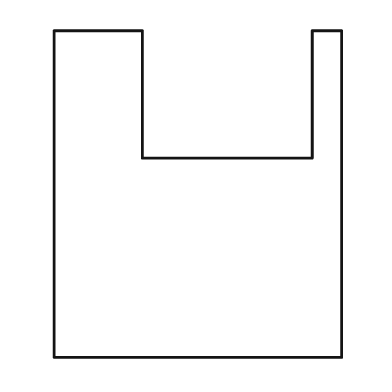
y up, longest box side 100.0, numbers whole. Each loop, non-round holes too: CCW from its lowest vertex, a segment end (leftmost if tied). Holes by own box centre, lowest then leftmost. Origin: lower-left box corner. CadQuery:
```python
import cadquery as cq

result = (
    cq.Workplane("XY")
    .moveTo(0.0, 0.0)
    .lineTo(88.0, 0.0)
    .lineTo(88.0, 100.0)
    .lineTo(79.0, 100.0)
    .lineTo(79.0, 61.0)
    .lineTo(27.0, 61.0)
    .lineTo(27.0, 100.0)
    .lineTo(0.0, 100.0)
    .close()
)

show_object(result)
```